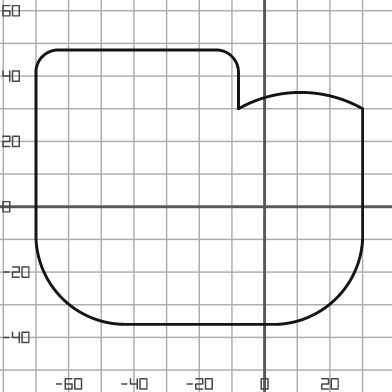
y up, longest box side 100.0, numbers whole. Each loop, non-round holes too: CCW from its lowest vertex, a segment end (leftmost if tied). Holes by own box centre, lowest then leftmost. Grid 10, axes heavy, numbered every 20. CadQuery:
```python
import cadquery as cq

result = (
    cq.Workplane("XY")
    .moveTo(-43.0, -36.0)
    .lineTo(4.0, -36.0)
    .threePointArc((22.0, -28.0), (30.0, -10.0))
    .lineTo(30.0, 30.0)
    .threePointArc((11.0, 35.0), (-8.0, 30.0))
    .lineTo(-8.0, 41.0)
    .threePointArc((-10.0, 46.0), (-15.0, 48.0))
    .lineTo(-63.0, 48.0)
    .threePointArc((-68.0, 46.0), (-70.0, 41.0))
    .lineTo(-70.0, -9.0)
    .threePointArc((-62.0, -28.0), (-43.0, -36.0))
    .close()
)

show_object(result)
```